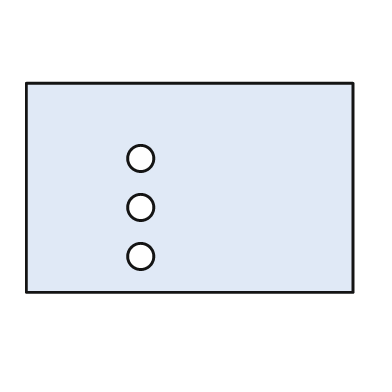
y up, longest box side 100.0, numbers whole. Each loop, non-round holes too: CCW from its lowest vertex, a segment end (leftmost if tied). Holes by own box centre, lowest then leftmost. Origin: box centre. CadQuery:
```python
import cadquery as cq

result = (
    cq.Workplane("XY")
    .moveTo(-50.0, -32.0)
    .lineTo(50.0, -32.0)
    .lineTo(50.0, 32.0)
    .lineTo(-50.0, 32.0)
    .close()
    .moveTo(-15.0, -21.0)
    .circle(4.0)
    .moveTo(-15.0, -6.0)
    .circle(4.0)
    .moveTo(-15.0, 9.0)
    .circle(4.0)
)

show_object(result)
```